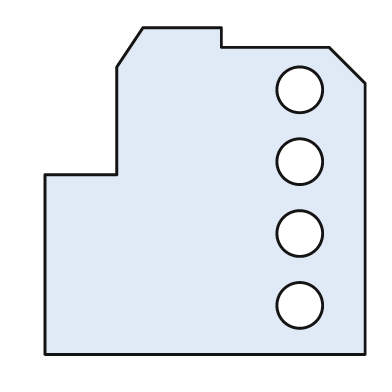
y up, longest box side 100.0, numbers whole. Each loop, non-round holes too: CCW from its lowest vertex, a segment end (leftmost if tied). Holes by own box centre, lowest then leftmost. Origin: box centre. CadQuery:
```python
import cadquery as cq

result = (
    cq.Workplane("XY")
    .moveTo(-49.0, -50.0)
    .lineTo(49.0, -50.0)
    .lineTo(49.0, 33.0)
    .lineTo(38.0, 44.0)
    .lineTo(5.0, 44.0)
    .lineTo(5.0, 50.0)
    .lineTo(-19.0, 50.0)
    .lineTo(-27.0, 38.0)
    .lineTo(-27.0, 5.0)
    .lineTo(-49.0, 5.0)
    .close()
    .moveTo(29.0, -35.0)
    .circle(7.0)
    .moveTo(29.0, -13.0)
    .circle(7.0)
    .moveTo(29.0, 9.0)
    .circle(7.0)
    .moveTo(29.0, 31.0)
    .circle(7.0)
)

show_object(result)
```